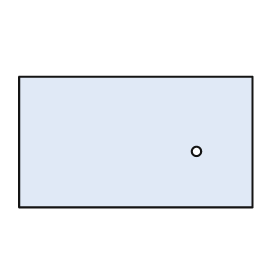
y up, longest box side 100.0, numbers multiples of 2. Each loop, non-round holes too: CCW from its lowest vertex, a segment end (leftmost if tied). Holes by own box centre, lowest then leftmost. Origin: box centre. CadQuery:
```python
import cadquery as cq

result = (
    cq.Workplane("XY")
    .moveTo(-50.0, -28.0)
    .lineTo(50.0, -28.0)
    .lineTo(50.0, 28.0)
    .lineTo(-50.0, 28.0)
    .close()
    .moveTo(26.0, -4.0)
    .circle(2.0)
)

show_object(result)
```